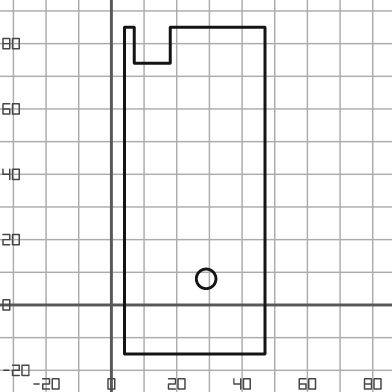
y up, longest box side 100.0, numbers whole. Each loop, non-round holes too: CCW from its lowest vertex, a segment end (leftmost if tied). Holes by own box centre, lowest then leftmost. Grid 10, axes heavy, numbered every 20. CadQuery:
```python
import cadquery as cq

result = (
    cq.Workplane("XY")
    .moveTo(4.0, -15.0)
    .lineTo(47.0, -15.0)
    .lineTo(47.0, 85.0)
    .lineTo(18.0, 85.0)
    .lineTo(18.0, 74.0)
    .lineTo(7.0, 74.0)
    .lineTo(7.0, 85.0)
    .lineTo(4.0, 85.0)
    .close()
    .moveTo(29.0, 8.0)
    .circle(3.0)
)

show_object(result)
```